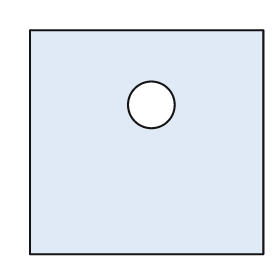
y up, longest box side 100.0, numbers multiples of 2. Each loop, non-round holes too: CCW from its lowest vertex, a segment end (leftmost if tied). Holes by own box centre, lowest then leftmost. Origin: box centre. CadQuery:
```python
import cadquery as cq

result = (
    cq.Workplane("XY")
    .moveTo(-50.0, -48.0)
    .lineTo(50.0, -48.0)
    .lineTo(50.0, 48.0)
    .lineTo(-50.0, 48.0)
    .close()
    .moveTo(2.0, 16.0)
    .circle(10.0)
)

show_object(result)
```